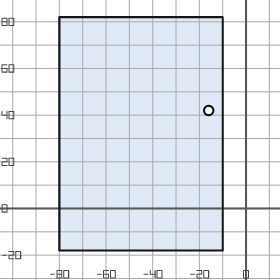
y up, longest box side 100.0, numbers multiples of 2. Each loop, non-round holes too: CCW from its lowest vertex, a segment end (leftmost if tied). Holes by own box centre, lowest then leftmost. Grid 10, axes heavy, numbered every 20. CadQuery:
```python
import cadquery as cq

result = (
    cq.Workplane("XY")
    .moveTo(-80.0, -18.0)
    .lineTo(-10.0, -18.0)
    .lineTo(-10.0, 82.0)
    .lineTo(-80.0, 82.0)
    .close()
    .moveTo(-16.0, 42.0)
    .circle(2.0)
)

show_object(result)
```